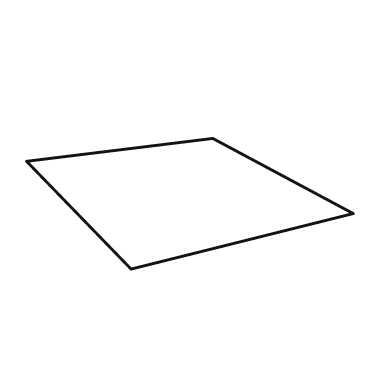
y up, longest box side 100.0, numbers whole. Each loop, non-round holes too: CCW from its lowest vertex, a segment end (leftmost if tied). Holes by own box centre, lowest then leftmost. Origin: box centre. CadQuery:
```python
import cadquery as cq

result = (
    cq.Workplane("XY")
    .moveTo(-18.0, -20.0)
    .lineTo(50.0, -3.0)
    .lineTo(7.0, 20.0)
    .lineTo(-50.0, 13.0)
    .close()
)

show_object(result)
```